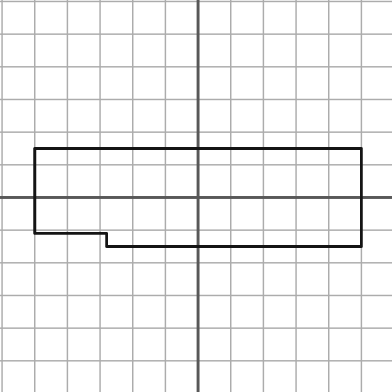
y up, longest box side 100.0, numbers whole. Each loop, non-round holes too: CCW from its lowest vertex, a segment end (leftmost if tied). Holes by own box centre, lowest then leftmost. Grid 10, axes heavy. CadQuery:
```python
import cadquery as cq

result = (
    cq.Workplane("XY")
    .moveTo(-28.0, -15.0)
    .lineTo(50.0, -15.0)
    .lineTo(50.0, 15.0)
    .lineTo(-50.0, 15.0)
    .lineTo(-50.0, -11.0)
    .lineTo(-28.0, -11.0)
    .close()
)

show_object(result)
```